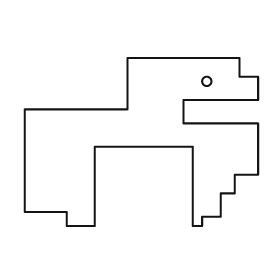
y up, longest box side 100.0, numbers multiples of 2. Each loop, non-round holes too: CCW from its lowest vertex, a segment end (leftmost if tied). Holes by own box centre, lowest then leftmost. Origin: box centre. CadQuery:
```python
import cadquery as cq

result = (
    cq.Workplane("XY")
    .moveTo(-32.0, -36.0)
    .lineTo(-20.0, -36.0)
    .lineTo(-20.0, -2.0)
    .lineTo(22.0, -2.0)
    .lineTo(22.0, -36.0)
    .lineTo(26.0, -36.0)
    .lineTo(26.0, -32.0)
    .lineTo(34.0, -32.0)
    .lineTo(34.0, -22.0)
    .lineTo(40.0, -22.0)
    .lineTo(40.0, -14.0)
    .lineTo(50.0, -14.0)
    .lineTo(50.0, 8.0)
    .lineTo(18.0, 8.0)
    .lineTo(18.0, 18.0)
    .lineTo(50.0, 18.0)
    .lineTo(50.0, 28.0)
    .lineTo(42.0, 28.0)
    .lineTo(42.0, 36.0)
    .lineTo(-6.0, 36.0)
    .lineTo(-6.0, 14.0)
    .lineTo(-50.0, 14.0)
    .lineTo(-50.0, -30.0)
    .lineTo(-32.0, -30.0)
    .close()
    .moveTo(28.0, 26.0)
    .circle(2.0)
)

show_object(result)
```